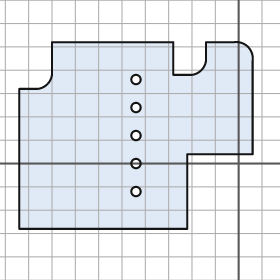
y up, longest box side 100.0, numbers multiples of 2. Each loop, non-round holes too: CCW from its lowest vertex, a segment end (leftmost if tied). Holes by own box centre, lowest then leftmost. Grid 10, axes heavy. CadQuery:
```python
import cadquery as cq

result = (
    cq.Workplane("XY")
    .moveTo(-94.0, -28.0)
    .lineTo(-22.0, -28.0)
    .lineTo(-22.0, 4.0)
    .lineTo(6.0, 4.0)
    .lineTo(6.0, 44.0)
    .threePointArc((4.0, 50.0), (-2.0, 52.0))
    .lineTo(-14.0, 52.0)
    .lineTo(-14.0, 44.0)
    .threePointArc((-16.0, 40.0), (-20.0, 38.0))
    .lineTo(-28.0, 38.0)
    .lineTo(-28.0, 52.0)
    .lineTo(-80.0, 52.0)
    .lineTo(-80.0, 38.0)
    .threePointArc((-82.0, 34.0), (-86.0, 32.0))
    .lineTo(-94.0, 32.0)
    .close()
    .moveTo(-44.0, -12.0)
    .circle(2.0)
    .moveTo(-44.0, 0.0)
    .circle(2.0)
    .moveTo(-44.0, 12.0)
    .circle(2.0)
    .moveTo(-44.0, 24.0)
    .circle(2.0)
    .moveTo(-44.0, 36.0)
    .circle(2.0)
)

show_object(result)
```